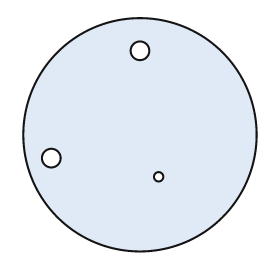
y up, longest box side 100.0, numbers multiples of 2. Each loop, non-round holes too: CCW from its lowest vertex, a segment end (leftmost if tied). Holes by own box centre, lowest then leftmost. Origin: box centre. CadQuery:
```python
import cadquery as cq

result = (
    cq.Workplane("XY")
    .moveTo(0.0, 0.0)
    .circle(50.0)
    .moveTo(8.0, -18.0)
    .circle(2.0)
    .moveTo(-38.0, -10.0)
    .circle(4.0)
    .moveTo(0.0, 36.0)
    .circle(4.0)
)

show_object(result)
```